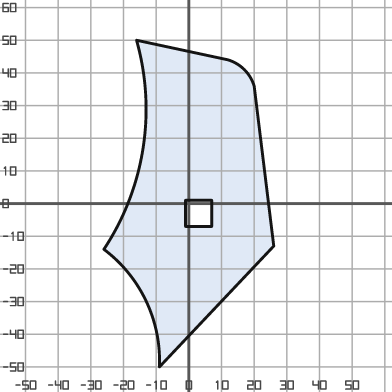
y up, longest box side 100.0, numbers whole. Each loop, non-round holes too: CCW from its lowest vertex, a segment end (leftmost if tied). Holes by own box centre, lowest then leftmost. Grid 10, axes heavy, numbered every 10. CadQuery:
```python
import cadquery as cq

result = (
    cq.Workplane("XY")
    .moveTo(-9.0, -50.0)
    .lineTo(26.0, -13.0)
    .lineTo(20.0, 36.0)
    .threePointArc((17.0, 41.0), (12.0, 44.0))
    .lineTo(-16.0, 50.0)
    .threePointArc((-14.0, 17.0), (-26.0, -14.0))
    .threePointArc((-13.0, -30.0), (-9.0, -50.0))
    .close()
    .moveTo(-1.0, -7.0)
    .lineTo(7.0, -7.0)
    .lineTo(7.0, 1.0)
    .lineTo(-1.0, 1.0)
    .close()
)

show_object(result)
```